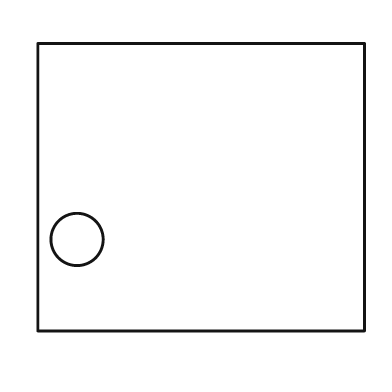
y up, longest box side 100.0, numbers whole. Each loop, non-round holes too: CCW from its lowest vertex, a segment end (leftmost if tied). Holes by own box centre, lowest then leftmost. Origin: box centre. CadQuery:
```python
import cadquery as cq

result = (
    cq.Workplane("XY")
    .moveTo(-50.0, -44.0)
    .lineTo(50.0, -44.0)
    .lineTo(50.0, 44.0)
    .lineTo(-50.0, 44.0)
    .close()
    .moveTo(-38.0, -16.0)
    .circle(8.0)
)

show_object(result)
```